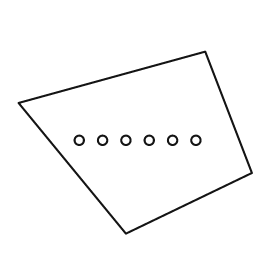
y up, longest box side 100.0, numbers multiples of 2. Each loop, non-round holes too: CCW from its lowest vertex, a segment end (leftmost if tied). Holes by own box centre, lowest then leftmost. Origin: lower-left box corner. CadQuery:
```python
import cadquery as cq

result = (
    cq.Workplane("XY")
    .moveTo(46.0, 0.0)
    .lineTo(100.0, 26.0)
    .lineTo(80.0, 78.0)
    .lineTo(0.0, 56.0)
    .close()
    .moveTo(26.0, 40.0)
    .circle(2.0)
    .moveTo(36.0, 40.0)
    .circle(2.0)
    .moveTo(46.0, 40.0)
    .circle(2.0)
    .moveTo(56.0, 40.0)
    .circle(2.0)
    .moveTo(66.0, 40.0)
    .circle(2.0)
    .moveTo(76.0, 40.0)
    .circle(2.0)
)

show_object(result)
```